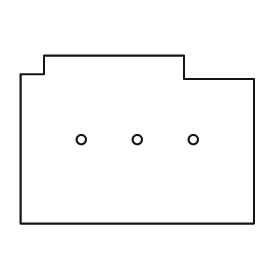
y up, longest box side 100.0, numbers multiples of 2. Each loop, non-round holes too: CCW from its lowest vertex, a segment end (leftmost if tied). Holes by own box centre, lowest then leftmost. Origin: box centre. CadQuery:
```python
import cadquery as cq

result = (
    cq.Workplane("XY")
    .moveTo(-50.0, -36.0)
    .lineTo(50.0, -36.0)
    .lineTo(50.0, 26.0)
    .lineTo(20.0, 26.0)
    .lineTo(20.0, 36.0)
    .lineTo(-40.0, 36.0)
    .lineTo(-40.0, 28.0)
    .lineTo(-50.0, 28.0)
    .close()
    .moveTo(-24.0, 0.0)
    .circle(2.0)
    .moveTo(0.0, 0.0)
    .circle(2.0)
    .moveTo(24.0, 0.0)
    .circle(2.0)
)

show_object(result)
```